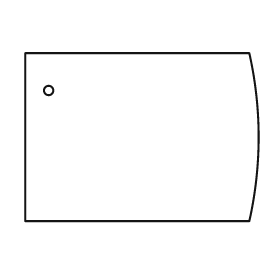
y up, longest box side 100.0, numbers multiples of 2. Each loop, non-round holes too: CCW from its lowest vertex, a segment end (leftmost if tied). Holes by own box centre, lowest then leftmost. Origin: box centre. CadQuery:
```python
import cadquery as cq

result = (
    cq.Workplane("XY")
    .moveTo(-50.0, -36.0)
    .lineTo(46.0, -36.0)
    .threePointArc((50.0, 0.0), (46.0, 36.0))
    .lineTo(-50.0, 36.0)
    .close()
    .moveTo(-40.0, 20.0)
    .circle(2.0)
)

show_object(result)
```